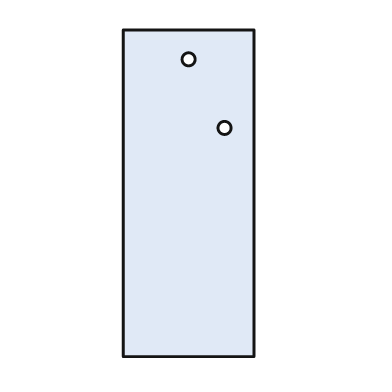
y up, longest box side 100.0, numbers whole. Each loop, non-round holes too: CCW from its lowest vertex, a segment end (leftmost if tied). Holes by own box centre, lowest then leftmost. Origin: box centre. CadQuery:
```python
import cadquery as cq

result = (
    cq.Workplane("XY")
    .moveTo(-20.0, -50.0)
    .lineTo(20.0, -50.0)
    .lineTo(20.0, 50.0)
    .lineTo(-20.0, 50.0)
    .close()
    .moveTo(11.0, 20.0)
    .circle(2.0)
    .moveTo(0.0, 41.0)
    .circle(2.0)
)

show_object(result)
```